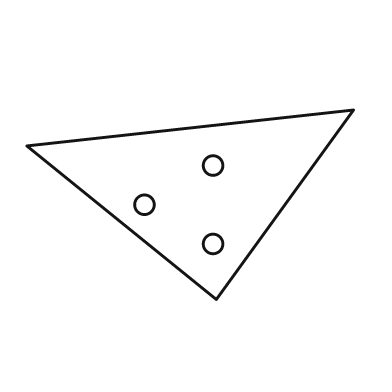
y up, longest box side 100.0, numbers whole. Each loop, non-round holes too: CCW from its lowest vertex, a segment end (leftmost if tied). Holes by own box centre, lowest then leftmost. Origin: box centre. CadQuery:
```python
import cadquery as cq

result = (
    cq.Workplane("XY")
    .moveTo(8.0, -29.0)
    .lineTo(50.0, 29.0)
    .lineTo(-50.0, 18.0)
    .close()
    .moveTo(7.0, -12.0)
    .circle(3.0)
    .moveTo(-14.0, 0.0)
    .circle(3.0)
    .moveTo(7.0, 12.0)
    .circle(3.0)
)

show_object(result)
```